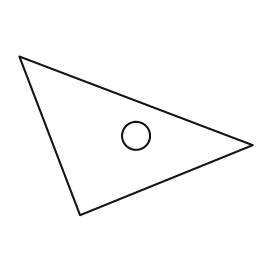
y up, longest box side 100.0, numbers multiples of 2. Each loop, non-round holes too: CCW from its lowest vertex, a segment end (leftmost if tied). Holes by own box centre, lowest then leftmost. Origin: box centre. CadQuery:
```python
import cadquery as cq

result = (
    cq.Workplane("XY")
    .moveTo(-24.0, -34.0)
    .lineTo(50.0, -4.0)
    .lineTo(-50.0, 34.0)
    .close()
    .moveTo(0.0, 0.0)
    .circle(6.0)
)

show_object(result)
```